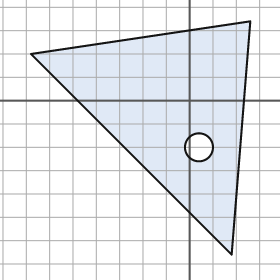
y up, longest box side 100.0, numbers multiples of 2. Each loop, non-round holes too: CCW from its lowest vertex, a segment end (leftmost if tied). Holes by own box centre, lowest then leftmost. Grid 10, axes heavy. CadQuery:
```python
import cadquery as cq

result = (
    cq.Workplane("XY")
    .moveTo(18.0, -66.0)
    .lineTo(26.0, 34.0)
    .lineTo(-68.0, 20.0)
    .close()
    .moveTo(4.0, -20.0)
    .circle(6.0)
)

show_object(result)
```